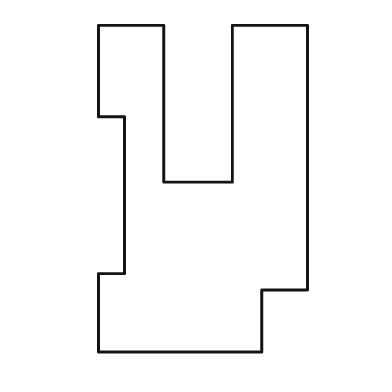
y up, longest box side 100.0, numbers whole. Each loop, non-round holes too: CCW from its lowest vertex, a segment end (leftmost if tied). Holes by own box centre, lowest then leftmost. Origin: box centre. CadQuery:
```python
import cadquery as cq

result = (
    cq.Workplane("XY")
    .moveTo(-32.0, -50.0)
    .lineTo(18.0, -50.0)
    .lineTo(18.0, -31.0)
    .lineTo(32.0, -31.0)
    .lineTo(32.0, 50.0)
    .lineTo(9.0, 50.0)
    .lineTo(9.0, 2.0)
    .lineTo(-12.0, 2.0)
    .lineTo(-12.0, 50.0)
    .lineTo(-32.0, 50.0)
    .lineTo(-32.0, 22.0)
    .lineTo(-24.0, 22.0)
    .lineTo(-24.0, -26.0)
    .lineTo(-32.0, -26.0)
    .close()
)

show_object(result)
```